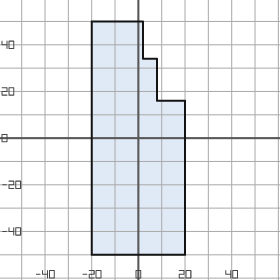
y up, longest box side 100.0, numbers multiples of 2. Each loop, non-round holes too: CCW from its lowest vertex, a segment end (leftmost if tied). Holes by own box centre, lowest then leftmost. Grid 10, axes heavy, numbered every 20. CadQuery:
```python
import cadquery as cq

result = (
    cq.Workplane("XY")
    .moveTo(-20.0, -50.0)
    .lineTo(20.0, -50.0)
    .lineTo(20.0, 16.0)
    .lineTo(8.0, 16.0)
    .lineTo(8.0, 34.0)
    .lineTo(2.0, 34.0)
    .lineTo(2.0, 50.0)
    .lineTo(-20.0, 50.0)
    .close()
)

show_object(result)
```